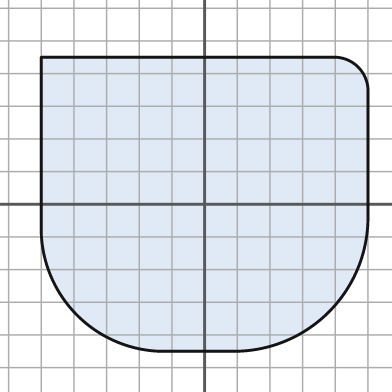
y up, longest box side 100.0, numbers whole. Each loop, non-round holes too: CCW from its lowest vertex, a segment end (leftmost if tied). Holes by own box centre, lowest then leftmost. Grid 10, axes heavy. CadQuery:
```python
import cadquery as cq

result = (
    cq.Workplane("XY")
    .moveTo(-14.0, -45.0)
    .lineTo(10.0, -45.0)
    .threePointArc((38.0, -33.0), (50.0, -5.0))
    .lineTo(50.0, 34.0)
    .threePointArc((47.0, 42.0), (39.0, 45.0))
    .lineTo(-50.0, 45.0)
    .lineTo(-50.0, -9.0)
    .threePointArc((-39.0, -34.0), (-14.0, -45.0))
    .close()
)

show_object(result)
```